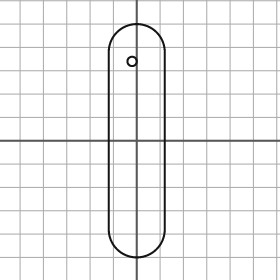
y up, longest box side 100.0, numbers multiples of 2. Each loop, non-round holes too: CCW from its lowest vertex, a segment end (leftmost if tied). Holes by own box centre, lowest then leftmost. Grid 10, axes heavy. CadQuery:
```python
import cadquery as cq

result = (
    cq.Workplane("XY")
    .moveTo(-12.0, -38.0)
    .threePointArc((0.0, -50.0), (12.0, -38.0))
    .lineTo(12.0, 38.0)
    .threePointArc((0.0, 50.0), (-12.0, 38.0))
    .close()
    .moveTo(-2.0, 34.0)
    .circle(2.0)
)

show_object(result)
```